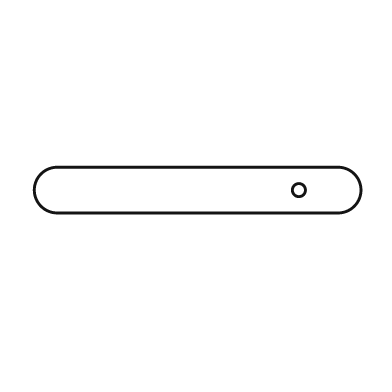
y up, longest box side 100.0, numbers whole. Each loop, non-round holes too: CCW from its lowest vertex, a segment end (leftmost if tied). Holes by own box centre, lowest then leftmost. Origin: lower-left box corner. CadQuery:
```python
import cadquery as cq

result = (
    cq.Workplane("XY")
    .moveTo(7.0, 0.0)
    .lineTo(93.0, 0.0)
    .threePointArc((100.0, 7.0), (93.0, 14.0))
    .lineTo(7.0, 14.0)
    .threePointArc((0.0, 7.0), (7.0, 0.0))
    .close()
    .moveTo(81.0, 7.0)
    .circle(2.0)
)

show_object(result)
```